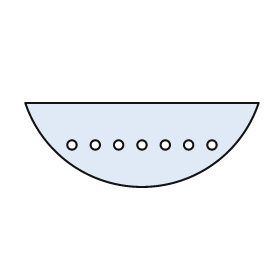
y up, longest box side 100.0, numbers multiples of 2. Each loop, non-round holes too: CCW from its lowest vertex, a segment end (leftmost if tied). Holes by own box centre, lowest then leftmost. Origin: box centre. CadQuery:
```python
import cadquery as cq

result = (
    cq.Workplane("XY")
    .moveTo(-50.0, 18.0)
    .threePointArc((0.0, -18.0), (50.0, 18.0))
    .close()
    .moveTo(-30.0, 0.0)
    .circle(2.0)
    .moveTo(-20.0, 0.0)
    .circle(2.0)
    .moveTo(-10.0, 0.0)
    .circle(2.0)
    .moveTo(0.0, 0.0)
    .circle(2.0)
    .moveTo(10.0, 0.0)
    .circle(2.0)
    .moveTo(20.0, 0.0)
    .circle(2.0)
    .moveTo(30.0, 0.0)
    .circle(2.0)
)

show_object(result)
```